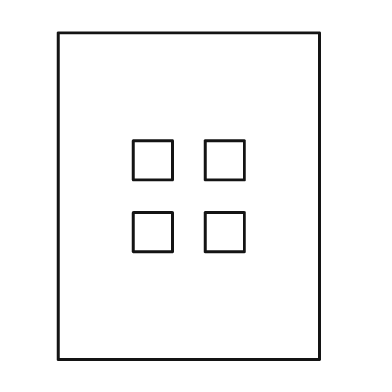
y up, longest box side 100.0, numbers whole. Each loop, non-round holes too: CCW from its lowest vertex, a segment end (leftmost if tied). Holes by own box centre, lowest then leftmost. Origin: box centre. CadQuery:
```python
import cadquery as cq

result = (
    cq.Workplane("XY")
    .moveTo(-40.0, -50.0)
    .lineTo(40.0, -50.0)
    .lineTo(40.0, 50.0)
    .lineTo(-40.0, 50.0)
    .close()
    .moveTo(-17.0, -17.0)
    .lineTo(-5.0, -17.0)
    .lineTo(-5.0, -5.0)
    .lineTo(-17.0, -5.0)
    .close()
    .moveTo(5.0, -17.0)
    .lineTo(17.0, -17.0)
    .lineTo(17.0, -5.0)
    .lineTo(5.0, -5.0)
    .close()
    .moveTo(-17.0, 5.0)
    .lineTo(-5.0, 5.0)
    .lineTo(-5.0, 17.0)
    .lineTo(-17.0, 17.0)
    .close()
    .moveTo(5.0, 5.0)
    .lineTo(17.0, 5.0)
    .lineTo(17.0, 17.0)
    .lineTo(5.0, 17.0)
    .close()
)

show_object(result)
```